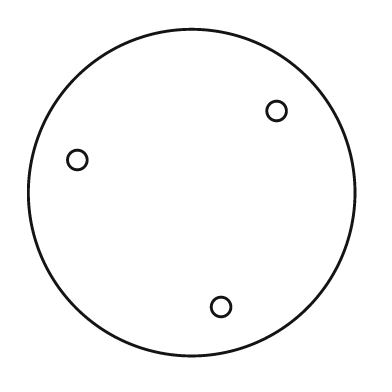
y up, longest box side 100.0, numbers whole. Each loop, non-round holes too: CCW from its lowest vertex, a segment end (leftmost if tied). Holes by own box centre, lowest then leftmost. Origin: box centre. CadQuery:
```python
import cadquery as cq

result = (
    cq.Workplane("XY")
    .moveTo(0.0, 0.0)
    .circle(50.0)
    .moveTo(9.0, -35.0)
    .circle(3.0)
    .moveTo(-35.0, 10.0)
    .circle(3.0)
    .moveTo(26.0, 25.0)
    .circle(3.0)
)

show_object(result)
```